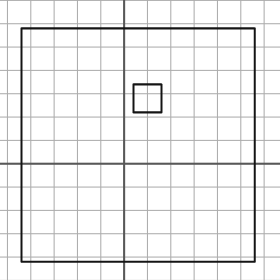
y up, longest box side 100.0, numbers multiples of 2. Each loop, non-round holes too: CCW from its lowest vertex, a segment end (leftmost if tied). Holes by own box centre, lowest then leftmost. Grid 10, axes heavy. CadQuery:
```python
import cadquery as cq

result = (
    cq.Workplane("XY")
    .moveTo(-44.0, -42.0)
    .lineTo(56.0, -42.0)
    .lineTo(56.0, 58.0)
    .lineTo(-44.0, 58.0)
    .close()
    .moveTo(4.0, 22.0)
    .lineTo(16.0, 22.0)
    .lineTo(16.0, 34.0)
    .lineTo(4.0, 34.0)
    .close()
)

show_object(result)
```